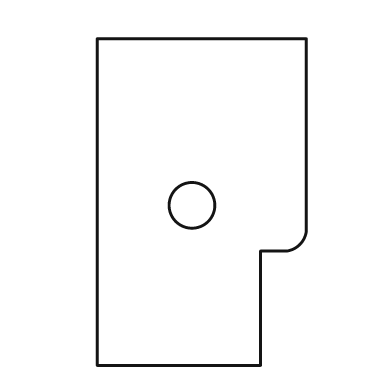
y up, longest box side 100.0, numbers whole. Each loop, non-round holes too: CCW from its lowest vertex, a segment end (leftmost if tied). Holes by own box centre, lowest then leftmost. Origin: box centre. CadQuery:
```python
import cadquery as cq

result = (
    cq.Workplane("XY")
    .moveTo(-32.0, -50.0)
    .lineTo(18.0, -50.0)
    .lineTo(18.0, -15.0)
    .lineTo(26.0, -15.0)
    .threePointArc((30.0, -13.0), (32.0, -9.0))
    .lineTo(32.0, 50.0)
    .lineTo(-32.0, 50.0)
    .close()
    .moveTo(-3.0, -1.0)
    .circle(7.0)
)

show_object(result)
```